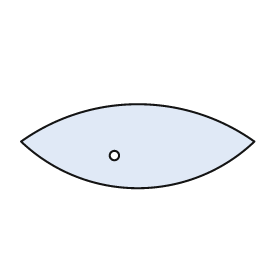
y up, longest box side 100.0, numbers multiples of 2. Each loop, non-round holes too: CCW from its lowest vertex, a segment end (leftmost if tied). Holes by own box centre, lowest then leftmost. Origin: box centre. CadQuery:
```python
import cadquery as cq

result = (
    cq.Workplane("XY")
    .moveTo(-50.0, 2.0)
    .threePointArc((0.0, -18.0), (50.0, 2.0))
    .threePointArc((0.0, 18.0), (-50.0, 2.0))
    .close()
    .moveTo(-10.0, -4.0)
    .circle(2.0)
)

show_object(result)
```